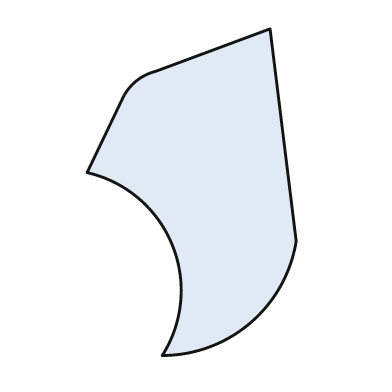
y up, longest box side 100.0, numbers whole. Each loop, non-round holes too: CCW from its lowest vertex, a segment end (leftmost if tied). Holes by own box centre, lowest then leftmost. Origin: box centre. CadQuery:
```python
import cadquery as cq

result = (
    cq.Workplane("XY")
    .moveTo(-9.0, -50.0)
    .threePointArc((18.0, -40.0), (32.0, -15.0))
    .lineTo(24.0, 50.0)
    .lineTo(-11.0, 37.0)
    .threePointArc((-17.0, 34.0), (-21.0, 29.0))
    .lineTo(-32.0, 6.0)
    .threePointArc((-6.0, -16.0), (-9.0, -50.0))
    .close()
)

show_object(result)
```